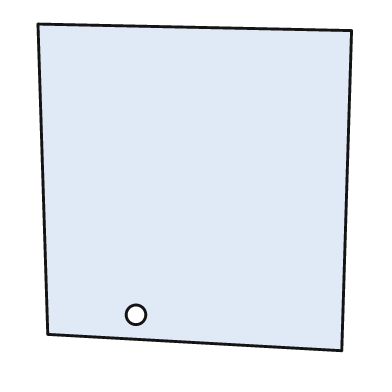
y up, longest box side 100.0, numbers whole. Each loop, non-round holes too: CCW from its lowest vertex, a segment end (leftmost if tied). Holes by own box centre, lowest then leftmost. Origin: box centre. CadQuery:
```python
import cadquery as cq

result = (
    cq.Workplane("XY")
    .moveTo(45.0, -50.0)
    .lineTo(48.0, 48.0)
    .lineTo(-48.0, 50.0)
    .lineTo(-45.0, -45.0)
    .close()
    .moveTo(-18.0, -39.0)
    .circle(3.0)
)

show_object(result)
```